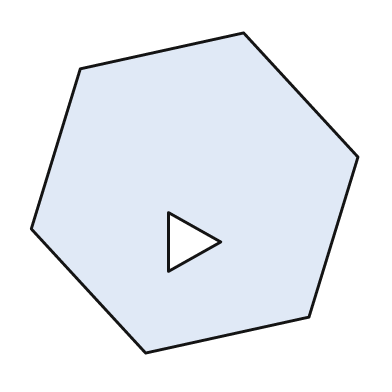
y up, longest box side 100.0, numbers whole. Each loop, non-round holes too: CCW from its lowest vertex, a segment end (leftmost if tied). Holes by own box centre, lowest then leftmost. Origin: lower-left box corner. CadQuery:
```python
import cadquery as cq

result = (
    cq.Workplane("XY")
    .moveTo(35.0, 0.0)
    .lineTo(85.0, 11.0)
    .lineTo(100.0, 60.0)
    .lineTo(65.0, 98.0)
    .lineTo(15.0, 87.0)
    .lineTo(0.0, 38.0)
    .close()
    .moveTo(42.0, 25.0)
    .lineTo(58.0, 34.0)
    .lineTo(42.0, 43.0)
    .close()
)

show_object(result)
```